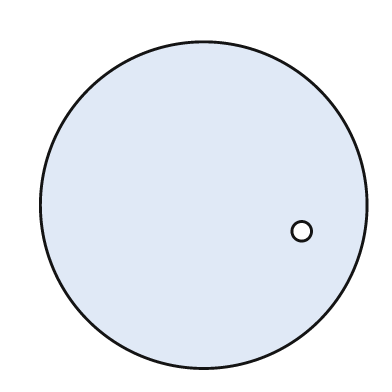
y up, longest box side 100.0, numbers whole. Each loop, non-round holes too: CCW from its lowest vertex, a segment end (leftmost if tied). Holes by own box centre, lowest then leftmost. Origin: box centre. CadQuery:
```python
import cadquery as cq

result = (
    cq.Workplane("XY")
    .moveTo(0.0, 0.0)
    .circle(50.0)
    .moveTo(30.0, -8.0)
    .circle(3.0)
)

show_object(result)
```